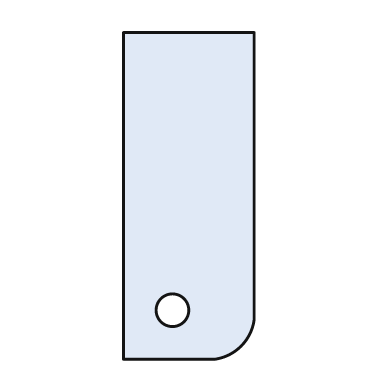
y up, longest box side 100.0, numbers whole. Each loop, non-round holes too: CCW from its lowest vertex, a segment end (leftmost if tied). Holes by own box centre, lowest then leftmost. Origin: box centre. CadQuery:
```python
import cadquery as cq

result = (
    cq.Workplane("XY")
    .moveTo(-20.0, -50.0)
    .lineTo(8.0, -50.0)
    .threePointArc((16.0, -46.0), (20.0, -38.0))
    .lineTo(20.0, 50.0)
    .lineTo(-20.0, 50.0)
    .close()
    .moveTo(-5.0, -35.0)
    .circle(5.0)
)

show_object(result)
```